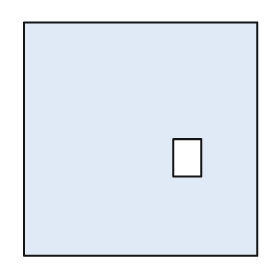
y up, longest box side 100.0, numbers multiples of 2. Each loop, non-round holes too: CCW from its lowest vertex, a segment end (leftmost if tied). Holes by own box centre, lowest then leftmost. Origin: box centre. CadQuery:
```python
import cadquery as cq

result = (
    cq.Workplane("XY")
    .moveTo(-50.0, -50.0)
    .lineTo(50.0, -50.0)
    .lineTo(50.0, 50.0)
    .lineTo(-50.0, 50.0)
    .close()
    .moveTo(14.0, -16.0)
    .lineTo(26.0, -16.0)
    .lineTo(26.0, 0.0)
    .lineTo(14.0, 0.0)
    .close()
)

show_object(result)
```